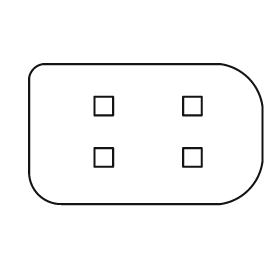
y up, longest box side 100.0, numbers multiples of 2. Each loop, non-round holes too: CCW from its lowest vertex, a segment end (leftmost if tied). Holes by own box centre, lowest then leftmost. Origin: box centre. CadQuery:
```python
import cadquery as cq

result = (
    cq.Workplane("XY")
    .moveTo(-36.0, -30.0)
    .lineTo(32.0, -30.0)
    .threePointArc((44.0, -24.0), (50.0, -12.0))
    .lineTo(50.0, 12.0)
    .threePointArc((44.0, 24.0), (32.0, 30.0))
    .lineTo(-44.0, 30.0)
    .threePointArc((-48.0, 28.0), (-50.0, 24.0))
    .lineTo(-50.0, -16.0)
    .threePointArc((-46.0, -26.0), (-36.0, -30.0))
    .close()
    .moveTo(-22.0, -14.0)
    .lineTo(-14.0, -14.0)
    .lineTo(-14.0, -6.0)
    .lineTo(-22.0, -6.0)
    .close()
    .moveTo(16.0, -14.0)
    .lineTo(24.0, -14.0)
    .lineTo(24.0, -6.0)
    .lineTo(16.0, -6.0)
    .close()
    .moveTo(-22.0, 8.0)
    .lineTo(-14.0, 8.0)
    .lineTo(-14.0, 16.0)
    .lineTo(-22.0, 16.0)
    .close()
    .moveTo(16.0, 8.0)
    .lineTo(24.0, 8.0)
    .lineTo(24.0, 16.0)
    .lineTo(16.0, 16.0)
    .close()
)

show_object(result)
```